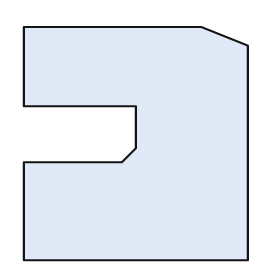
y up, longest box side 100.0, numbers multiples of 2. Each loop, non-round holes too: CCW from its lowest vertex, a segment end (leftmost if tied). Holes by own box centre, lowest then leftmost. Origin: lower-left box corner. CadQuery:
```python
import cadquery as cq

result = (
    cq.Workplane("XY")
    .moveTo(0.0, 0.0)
    .lineTo(96.0, 0.0)
    .lineTo(96.0, 92.0)
    .lineTo(76.0, 100.0)
    .lineTo(0.0, 100.0)
    .lineTo(0.0, 66.0)
    .lineTo(48.0, 66.0)
    .lineTo(48.0, 48.0)
    .lineTo(42.0, 42.0)
    .lineTo(0.0, 42.0)
    .close()
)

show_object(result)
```